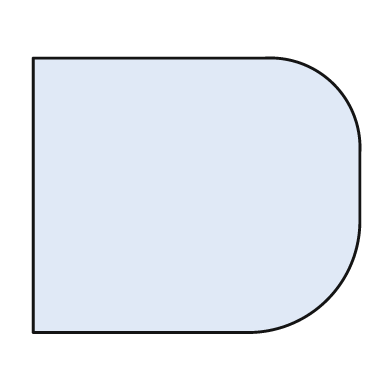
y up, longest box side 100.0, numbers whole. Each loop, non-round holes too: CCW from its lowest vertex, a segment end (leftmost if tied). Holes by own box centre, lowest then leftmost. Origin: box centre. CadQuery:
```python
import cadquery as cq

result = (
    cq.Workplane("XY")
    .moveTo(-50.0, -42.0)
    .lineTo(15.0, -42.0)
    .threePointArc((40.0, -32.0), (50.0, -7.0))
    .lineTo(50.0, 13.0)
    .threePointArc((42.0, 34.0), (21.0, 42.0))
    .lineTo(-50.0, 42.0)
    .close()
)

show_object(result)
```